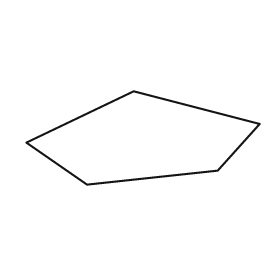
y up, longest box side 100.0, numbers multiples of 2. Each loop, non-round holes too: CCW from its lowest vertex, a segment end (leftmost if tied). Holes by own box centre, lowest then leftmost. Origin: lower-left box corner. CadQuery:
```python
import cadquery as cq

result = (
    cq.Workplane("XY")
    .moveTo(26.0, 0.0)
    .lineTo(82.0, 6.0)
    .lineTo(100.0, 26.0)
    .lineTo(46.0, 40.0)
    .lineTo(0.0, 18.0)
    .close()
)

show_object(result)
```